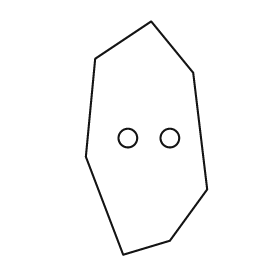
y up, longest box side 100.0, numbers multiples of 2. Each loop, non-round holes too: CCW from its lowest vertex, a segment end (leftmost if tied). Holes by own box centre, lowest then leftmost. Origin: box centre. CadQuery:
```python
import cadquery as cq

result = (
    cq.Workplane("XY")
    .moveTo(-10.0, -50.0)
    .lineTo(10.0, -44.0)
    .lineTo(26.0, -22.0)
    .lineTo(20.0, 28.0)
    .lineTo(2.0, 50.0)
    .lineTo(-22.0, 34.0)
    .lineTo(-26.0, -8.0)
    .close()
    .moveTo(-8.0, 0.0)
    .circle(4.0)
    .moveTo(10.0, 0.0)
    .circle(4.0)
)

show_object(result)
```